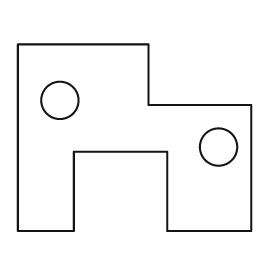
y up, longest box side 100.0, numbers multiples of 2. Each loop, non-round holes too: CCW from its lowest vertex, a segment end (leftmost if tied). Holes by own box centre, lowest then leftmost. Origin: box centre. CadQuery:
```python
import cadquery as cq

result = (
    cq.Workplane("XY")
    .moveTo(-50.0, -40.0)
    .lineTo(-26.0, -40.0)
    .lineTo(-26.0, -6.0)
    .lineTo(14.0, -6.0)
    .lineTo(14.0, -40.0)
    .lineTo(50.0, -40.0)
    .lineTo(50.0, 14.0)
    .lineTo(6.0, 14.0)
    .lineTo(6.0, 40.0)
    .lineTo(-50.0, 40.0)
    .close()
    .moveTo(36.0, -4.0)
    .circle(8.0)
    .moveTo(-32.0, 16.0)
    .circle(8.0)
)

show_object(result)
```